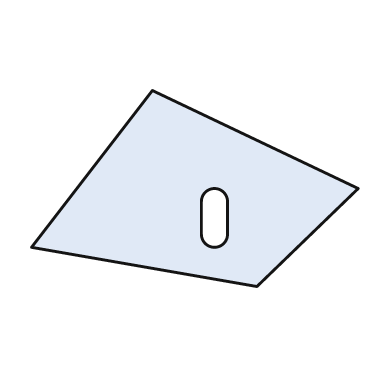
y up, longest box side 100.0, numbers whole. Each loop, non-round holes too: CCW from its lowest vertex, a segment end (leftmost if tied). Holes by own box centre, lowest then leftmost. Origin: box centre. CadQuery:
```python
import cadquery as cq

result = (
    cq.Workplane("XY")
    .moveTo(19.0, -30.0)
    .lineTo(50.0, 0.0)
    .lineTo(-13.0, 30.0)
    .lineTo(-50.0, -18.0)
    .close()
    .moveTo(2.0, -14.0)
    .threePointArc((6.0, -18.0), (10.0, -14.0))
    .lineTo(10.0, -4.0)
    .threePointArc((6.0, 0.0), (2.0, -4.0))
    .close()
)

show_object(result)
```